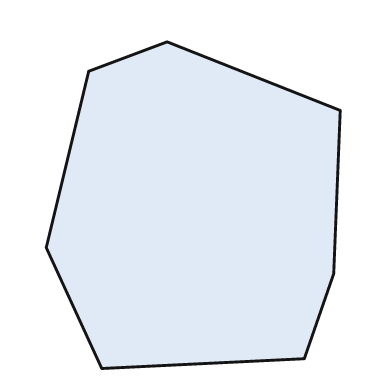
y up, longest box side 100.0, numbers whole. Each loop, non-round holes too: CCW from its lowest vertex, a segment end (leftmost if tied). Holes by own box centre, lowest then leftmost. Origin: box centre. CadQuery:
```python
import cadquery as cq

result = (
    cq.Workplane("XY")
    .moveTo(-28.0, -50.0)
    .lineTo(34.0, -47.0)
    .lineTo(43.0, -21.0)
    .lineTo(45.0, 29.0)
    .lineTo(-8.0, 50.0)
    .lineTo(-32.0, 41.0)
    .lineTo(-45.0, -13.0)
    .close()
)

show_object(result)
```